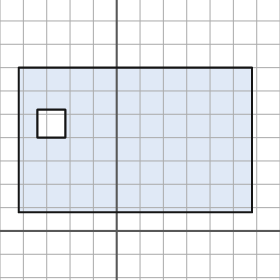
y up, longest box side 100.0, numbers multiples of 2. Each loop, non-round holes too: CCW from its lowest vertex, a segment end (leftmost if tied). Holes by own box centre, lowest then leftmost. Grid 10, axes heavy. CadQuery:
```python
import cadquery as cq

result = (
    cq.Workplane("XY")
    .moveTo(-42.0, 8.0)
    .lineTo(58.0, 8.0)
    .lineTo(58.0, 70.0)
    .lineTo(-42.0, 70.0)
    .close()
    .moveTo(-34.0, 40.0)
    .lineTo(-22.0, 40.0)
    .lineTo(-22.0, 52.0)
    .lineTo(-34.0, 52.0)
    .close()
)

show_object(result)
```